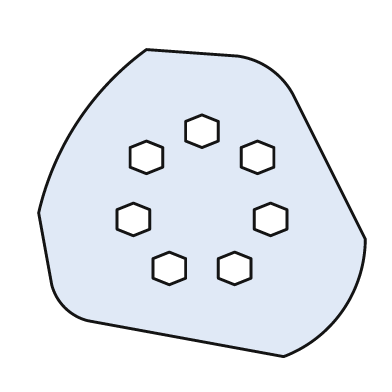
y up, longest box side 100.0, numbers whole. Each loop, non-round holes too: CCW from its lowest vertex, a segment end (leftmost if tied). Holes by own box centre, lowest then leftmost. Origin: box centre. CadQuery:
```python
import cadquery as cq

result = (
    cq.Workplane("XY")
    .moveTo(25.0, -47.0)
    .threePointArc((43.0, -33.0), (50.0, -11.0))
    .lineTo(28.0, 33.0)
    .threePointArc((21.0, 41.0), (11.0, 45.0))
    .lineTo(-17.0, 47.0)
    .threePointArc((-38.0, 25.0), (-50.0, -3.0))
    .lineTo(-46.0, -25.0)
    .threePointArc((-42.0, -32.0), (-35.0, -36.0))
    .close()
    .moveTo(-10.0, -25.0)
    .lineTo(-5.0, -23.0)
    .lineTo(-5.0, -17.0)
    .lineTo(-10.0, -15.0)
    .lineTo(-15.0, -17.0)
    .lineTo(-15.0, -23.0)
    .close()
    .moveTo(10.0, -25.0)
    .lineTo(15.0, -23.0)
    .lineTo(15.0, -17.0)
    .lineTo(10.0, -15.0)
    .lineTo(5.0, -17.0)
    .lineTo(5.0, -23.0)
    .close()
    .moveTo(-21.0, -10.0)
    .lineTo(-16.0, -8.0)
    .lineTo(-16.0, -2.0)
    .lineTo(-21.0, 0.0)
    .lineTo(-26.0, -2.0)
    .lineTo(-26.0, -8.0)
    .close()
    .moveTo(21.0, -10.0)
    .lineTo(26.0, -8.0)
    .lineTo(26.0, -2.0)
    .lineTo(21.0, 0.0)
    .lineTo(16.0, -2.0)
    .lineTo(16.0, -8.0)
    .close()
    .moveTo(-17.0, 9.0)
    .lineTo(-12.0, 11.0)
    .lineTo(-12.0, 17.0)
    .lineTo(-17.0, 19.0)
    .lineTo(-22.0, 17.0)
    .lineTo(-22.0, 11.0)
    .close()
    .moveTo(17.0, 9.0)
    .lineTo(22.0, 11.0)
    .lineTo(22.0, 17.0)
    .lineTo(17.0, 19.0)
    .lineTo(12.0, 17.0)
    .lineTo(12.0, 11.0)
    .close()
    .moveTo(0.0, 17.0)
    .lineTo(5.0, 19.0)
    .lineTo(5.0, 25.0)
    .lineTo(0.0, 27.0)
    .lineTo(-5.0, 25.0)
    .lineTo(-5.0, 19.0)
    .close()
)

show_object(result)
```